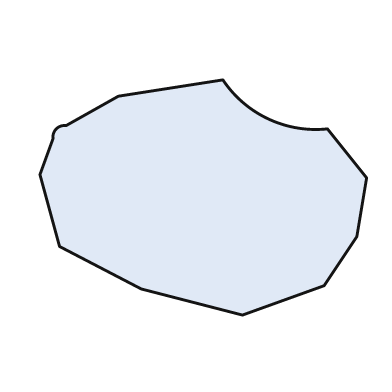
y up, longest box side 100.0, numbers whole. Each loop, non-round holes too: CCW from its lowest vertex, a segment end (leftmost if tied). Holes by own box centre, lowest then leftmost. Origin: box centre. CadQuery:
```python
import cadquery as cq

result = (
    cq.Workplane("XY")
    .moveTo(12.0, -36.0)
    .lineTo(37.0, -27.0)
    .lineTo(47.0, -12.0)
    .lineTo(50.0, 6.0)
    .lineTo(38.0, 21.0)
    .threePointArc((20.0, 24.0), (6.0, 36.0))
    .lineTo(-26.0, 31.0)
    .lineTo(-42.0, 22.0)
    .threePointArc((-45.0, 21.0), (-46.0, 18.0))
    .lineTo(-50.0, 7.0)
    .lineTo(-44.0, -15.0)
    .lineTo(-19.0, -28.0)
    .close()
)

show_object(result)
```